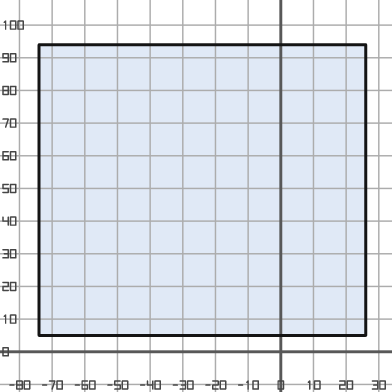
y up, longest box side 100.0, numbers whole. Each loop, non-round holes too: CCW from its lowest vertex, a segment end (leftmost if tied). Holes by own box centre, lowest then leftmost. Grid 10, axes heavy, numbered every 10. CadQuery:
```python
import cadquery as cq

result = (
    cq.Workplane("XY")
    .moveTo(-74.0, 5.0)
    .lineTo(26.0, 5.0)
    .lineTo(26.0, 94.0)
    .lineTo(-74.0, 94.0)
    .close()
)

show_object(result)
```